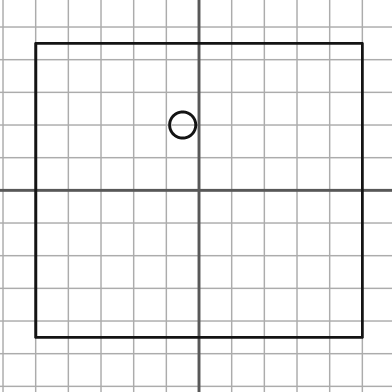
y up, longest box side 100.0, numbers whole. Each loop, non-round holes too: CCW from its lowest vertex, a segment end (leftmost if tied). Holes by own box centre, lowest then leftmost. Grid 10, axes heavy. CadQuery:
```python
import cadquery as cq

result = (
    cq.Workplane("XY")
    .moveTo(-50.0, -45.0)
    .lineTo(50.0, -45.0)
    .lineTo(50.0, 45.0)
    .lineTo(-50.0, 45.0)
    .close()
    .moveTo(-5.0, 20.0)
    .circle(4.0)
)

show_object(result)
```